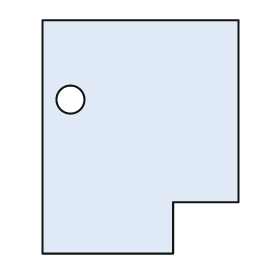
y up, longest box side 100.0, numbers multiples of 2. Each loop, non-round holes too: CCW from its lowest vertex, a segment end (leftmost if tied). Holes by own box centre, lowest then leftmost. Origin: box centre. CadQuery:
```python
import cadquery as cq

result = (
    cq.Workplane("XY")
    .moveTo(-42.0, -50.0)
    .lineTo(14.0, -50.0)
    .lineTo(14.0, -28.0)
    .lineTo(42.0, -28.0)
    .lineTo(42.0, 50.0)
    .lineTo(-42.0, 50.0)
    .close()
    .moveTo(-30.0, 16.0)
    .circle(6.0)
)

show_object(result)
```